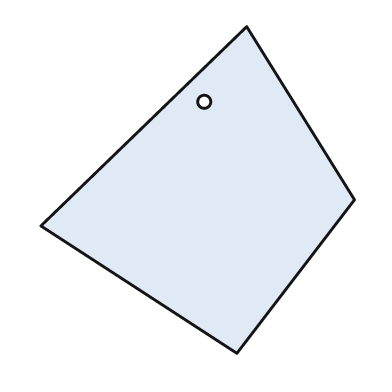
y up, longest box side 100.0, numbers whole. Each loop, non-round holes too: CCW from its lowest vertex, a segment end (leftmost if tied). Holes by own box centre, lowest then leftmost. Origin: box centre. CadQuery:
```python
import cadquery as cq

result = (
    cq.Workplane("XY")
    .moveTo(12.0, -50.0)
    .lineTo(48.0, -3.0)
    .lineTo(15.0, 50.0)
    .lineTo(-48.0, -11.0)
    .close()
    .moveTo(2.0, 27.0)
    .circle(2.0)
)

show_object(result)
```